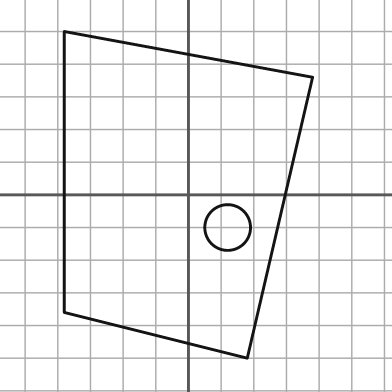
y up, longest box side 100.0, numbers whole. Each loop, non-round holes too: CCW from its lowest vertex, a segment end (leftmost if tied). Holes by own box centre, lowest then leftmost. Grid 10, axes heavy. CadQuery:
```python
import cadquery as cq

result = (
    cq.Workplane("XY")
    .moveTo(18.0, -50.0)
    .lineTo(38.0, 36.0)
    .lineTo(-38.0, 50.0)
    .lineTo(-38.0, -36.0)
    .close()
    .moveTo(12.0, -10.0)
    .circle(7.0)
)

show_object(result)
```